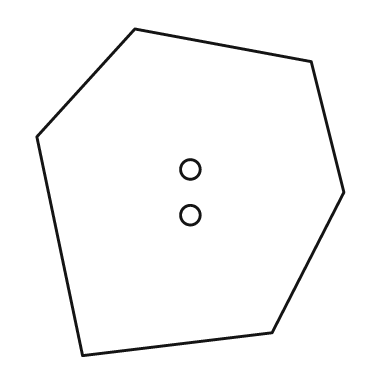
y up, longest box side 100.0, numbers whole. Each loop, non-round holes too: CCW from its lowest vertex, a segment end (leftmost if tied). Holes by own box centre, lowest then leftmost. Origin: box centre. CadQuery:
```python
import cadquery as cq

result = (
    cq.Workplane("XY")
    .moveTo(-33.0, -50.0)
    .lineTo(25.0, -43.0)
    .lineTo(47.0, 0.0)
    .lineTo(37.0, 40.0)
    .lineTo(-17.0, 50.0)
    .lineTo(-47.0, 17.0)
    .close()
    .moveTo(0.0, -7.0)
    .circle(3.0)
    .moveTo(0.0, 7.0)
    .circle(3.0)
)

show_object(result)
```